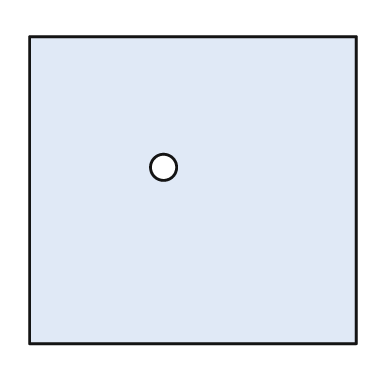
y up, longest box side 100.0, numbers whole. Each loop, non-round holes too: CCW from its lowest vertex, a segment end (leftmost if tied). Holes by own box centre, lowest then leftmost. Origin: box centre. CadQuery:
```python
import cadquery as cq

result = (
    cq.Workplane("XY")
    .moveTo(-50.0, -47.0)
    .lineTo(50.0, -47.0)
    .lineTo(50.0, 47.0)
    .lineTo(-50.0, 47.0)
    .close()
    .moveTo(-9.0, 7.0)
    .circle(4.0)
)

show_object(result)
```